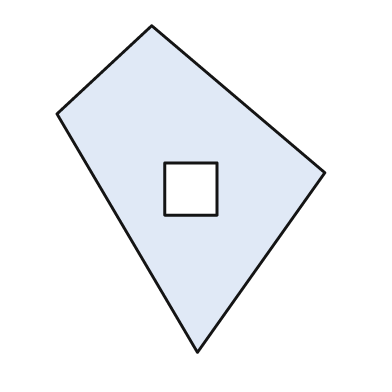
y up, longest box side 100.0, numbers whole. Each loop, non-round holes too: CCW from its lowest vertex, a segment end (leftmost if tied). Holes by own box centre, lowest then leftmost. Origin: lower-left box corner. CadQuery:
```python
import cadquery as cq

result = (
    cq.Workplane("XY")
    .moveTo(43.0, 0.0)
    .lineTo(82.0, 55.0)
    .lineTo(29.0, 100.0)
    .lineTo(0.0, 73.0)
    .close()
    .moveTo(33.0, 42.0)
    .lineTo(49.0, 42.0)
    .lineTo(49.0, 58.0)
    .lineTo(33.0, 58.0)
    .close()
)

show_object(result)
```